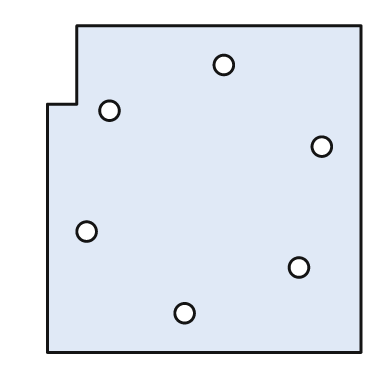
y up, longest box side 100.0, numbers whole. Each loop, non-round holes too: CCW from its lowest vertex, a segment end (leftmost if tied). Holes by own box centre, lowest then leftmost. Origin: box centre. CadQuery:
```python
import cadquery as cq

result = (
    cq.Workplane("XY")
    .moveTo(-48.0, -50.0)
    .lineTo(48.0, -50.0)
    .lineTo(48.0, 50.0)
    .lineTo(-39.0, 50.0)
    .lineTo(-39.0, 26.0)
    .lineTo(-48.0, 26.0)
    .close()
    .moveTo(-6.0, -38.0)
    .circle(3.0)
    .moveTo(29.0, -24.0)
    .circle(3.0)
    .moveTo(-36.0, -13.0)
    .circle(3.0)
    .moveTo(36.0, 13.0)
    .circle(3.0)
    .moveTo(-29.0, 24.0)
    .circle(3.0)
    .moveTo(6.0, 38.0)
    .circle(3.0)
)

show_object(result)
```